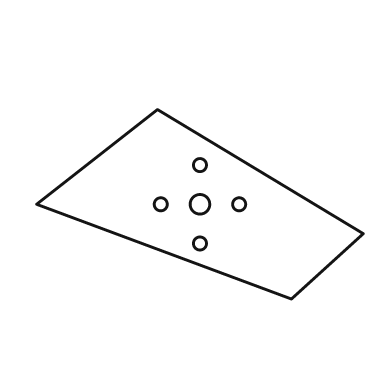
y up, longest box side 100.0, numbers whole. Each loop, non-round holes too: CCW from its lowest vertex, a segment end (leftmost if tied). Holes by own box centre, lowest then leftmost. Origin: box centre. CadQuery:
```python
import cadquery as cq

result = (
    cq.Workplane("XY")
    .moveTo(28.0, -29.0)
    .lineTo(50.0, -9.0)
    .lineTo(-13.0, 29.0)
    .lineTo(-50.0, 0.0)
    .close()
    .moveTo(0.0, -12.0)
    .circle(2.0)
    .moveTo(-12.0, 0.0)
    .circle(2.0)
    .moveTo(0.0, 0.0)
    .circle(3.0)
    .moveTo(12.0, 0.0)
    .circle(2.0)
    .moveTo(0.0, 12.0)
    .circle(2.0)
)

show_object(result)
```